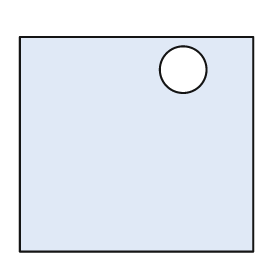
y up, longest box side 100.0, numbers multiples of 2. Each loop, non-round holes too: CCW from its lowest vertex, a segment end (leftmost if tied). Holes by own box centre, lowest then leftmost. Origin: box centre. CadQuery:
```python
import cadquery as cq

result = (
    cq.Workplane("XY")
    .moveTo(-50.0, -46.0)
    .lineTo(50.0, -46.0)
    .lineTo(50.0, 46.0)
    .lineTo(-50.0, 46.0)
    .close()
    .moveTo(20.0, 32.0)
    .circle(10.0)
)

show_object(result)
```